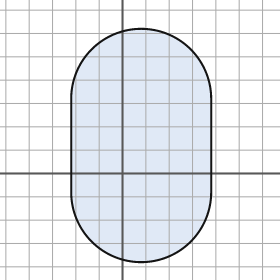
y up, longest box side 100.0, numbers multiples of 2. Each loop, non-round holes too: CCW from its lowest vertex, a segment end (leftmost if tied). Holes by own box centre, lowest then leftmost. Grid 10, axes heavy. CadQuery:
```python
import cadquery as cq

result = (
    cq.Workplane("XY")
    .moveTo(-22.0, -8.0)
    .threePointArc((8.0, -38.0), (38.0, -8.0))
    .lineTo(38.0, 32.0)
    .threePointArc((8.0, 62.0), (-22.0, 32.0))
    .close()
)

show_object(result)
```